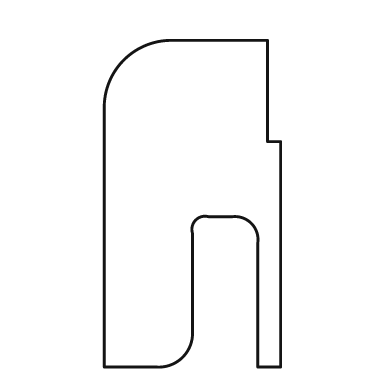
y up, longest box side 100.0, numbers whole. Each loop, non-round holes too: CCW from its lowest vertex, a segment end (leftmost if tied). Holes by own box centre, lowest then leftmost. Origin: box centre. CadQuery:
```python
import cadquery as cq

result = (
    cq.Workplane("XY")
    .moveTo(-27.0, -50.0)
    .lineTo(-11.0, -50.0)
    .threePointArc((-3.0, -47.0), (0.0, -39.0))
    .lineTo(0.0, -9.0)
    .threePointArc((1.0, -5.0), (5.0, -4.0))
    .lineTo(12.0, -4.0)
    .threePointArc((18.0, -6.0), (20.0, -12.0))
    .lineTo(20.0, -50.0)
    .lineTo(27.0, -50.0)
    .lineTo(27.0, 19.0)
    .lineTo(23.0, 19.0)
    .lineTo(23.0, 50.0)
    .lineTo(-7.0, 50.0)
    .threePointArc((-21.0, 44.0), (-27.0, 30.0))
    .close()
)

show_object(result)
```